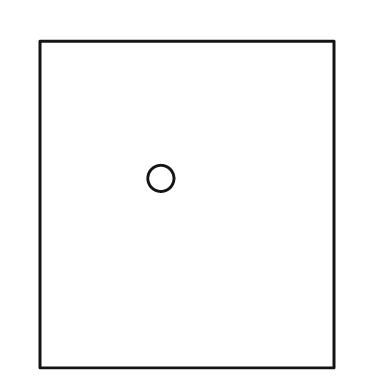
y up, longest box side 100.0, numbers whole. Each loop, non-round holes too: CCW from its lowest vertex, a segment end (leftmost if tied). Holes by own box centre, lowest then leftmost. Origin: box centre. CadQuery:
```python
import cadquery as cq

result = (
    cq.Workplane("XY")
    .moveTo(-45.0, -50.0)
    .lineTo(45.0, -50.0)
    .lineTo(45.0, 50.0)
    .lineTo(-45.0, 50.0)
    .close()
    .moveTo(-8.0, 8.0)
    .circle(4.0)
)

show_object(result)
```